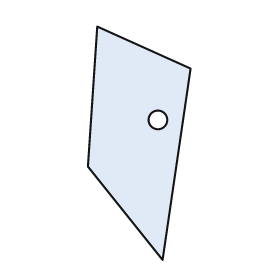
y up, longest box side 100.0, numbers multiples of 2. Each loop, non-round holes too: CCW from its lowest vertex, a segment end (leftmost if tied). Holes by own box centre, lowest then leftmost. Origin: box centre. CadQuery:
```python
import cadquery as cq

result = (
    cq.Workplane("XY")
    .moveTo(10.0, -50.0)
    .lineTo(22.0, 32.0)
    .lineTo(-18.0, 50.0)
    .lineTo(-22.0, -10.0)
    .close()
    .moveTo(8.0, 10.0)
    .circle(4.0)
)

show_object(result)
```